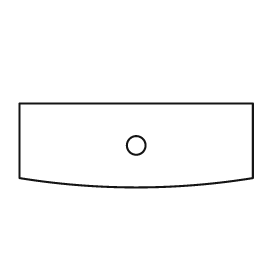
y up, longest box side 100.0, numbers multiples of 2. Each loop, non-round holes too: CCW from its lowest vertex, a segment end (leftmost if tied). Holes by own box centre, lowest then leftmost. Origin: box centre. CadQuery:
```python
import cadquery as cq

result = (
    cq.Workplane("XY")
    .moveTo(-50.0, -14.0)
    .threePointArc((0.0, -18.0), (50.0, -14.0))
    .lineTo(50.0, 18.0)
    .lineTo(-50.0, 18.0)
    .close()
    .moveTo(0.0, 0.0)
    .circle(4.0)
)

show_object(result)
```